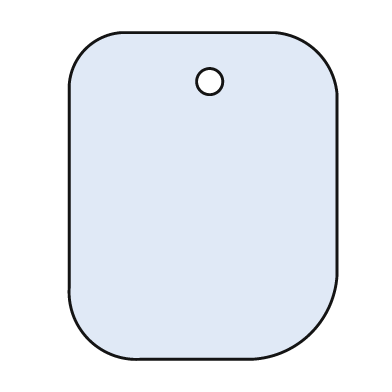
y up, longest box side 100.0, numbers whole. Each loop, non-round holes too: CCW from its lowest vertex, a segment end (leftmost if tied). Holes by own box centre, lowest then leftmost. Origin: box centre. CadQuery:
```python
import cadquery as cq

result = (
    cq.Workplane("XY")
    .moveTo(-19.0, -50.0)
    .lineTo(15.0, -50.0)
    .threePointArc((33.0, -42.0), (41.0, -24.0))
    .lineTo(41.0, 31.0)
    .threePointArc((35.0, 44.0), (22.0, 50.0))
    .lineTo(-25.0, 50.0)
    .threePointArc((-36.0, 45.0), (-41.0, 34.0))
    .lineTo(-41.0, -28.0)
    .threePointArc((-35.0, -44.0), (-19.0, -50.0))
    .close()
    .moveTo(2.0, 35.0)
    .circle(4.0)
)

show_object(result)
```